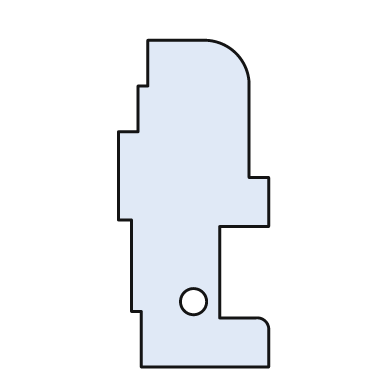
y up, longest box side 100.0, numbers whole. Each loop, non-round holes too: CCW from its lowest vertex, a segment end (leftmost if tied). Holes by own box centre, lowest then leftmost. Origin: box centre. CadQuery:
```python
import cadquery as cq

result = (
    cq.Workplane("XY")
    .moveTo(-16.0, -50.0)
    .lineTo(23.0, -50.0)
    .lineTo(23.0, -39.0)
    .threePointArc((22.0, -36.0), (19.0, -35.0))
    .lineTo(8.0, -35.0)
    .lineTo(8.0, -7.0)
    .lineTo(23.0, -7.0)
    .lineTo(23.0, 8.0)
    .lineTo(17.0, 8.0)
    .lineTo(17.0, 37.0)
    .threePointArc((13.0, 46.0), (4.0, 50.0))
    .lineTo(-14.0, 50.0)
    .lineTo(-14.0, 36.0)
    .lineTo(-17.0, 36.0)
    .lineTo(-17.0, 22.0)
    .lineTo(-23.0, 22.0)
    .lineTo(-23.0, -5.0)
    .lineTo(-19.0, -5.0)
    .lineTo(-19.0, -33.0)
    .lineTo(-16.0, -33.0)
    .close()
    .moveTo(0.0, -30.0)
    .circle(4.0)
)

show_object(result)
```